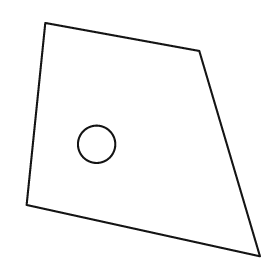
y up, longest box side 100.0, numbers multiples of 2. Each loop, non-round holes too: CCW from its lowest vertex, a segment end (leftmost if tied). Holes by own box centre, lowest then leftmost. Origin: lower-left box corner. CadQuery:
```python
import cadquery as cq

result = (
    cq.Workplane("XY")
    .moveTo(100.0, 0.0)
    .lineTo(74.0, 88.0)
    .lineTo(8.0, 100.0)
    .lineTo(0.0, 22.0)
    .close()
    .moveTo(30.0, 48.0)
    .circle(8.0)
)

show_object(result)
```